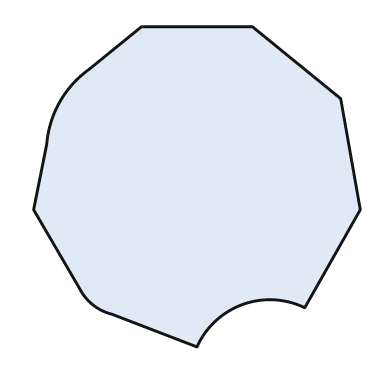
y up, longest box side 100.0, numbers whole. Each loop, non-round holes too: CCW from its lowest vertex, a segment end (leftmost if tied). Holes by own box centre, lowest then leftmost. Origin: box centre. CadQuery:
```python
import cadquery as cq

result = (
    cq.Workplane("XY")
    .moveTo(0.0, -49.0)
    .threePointArc((14.0, -36.0), (33.0, -37.0))
    .lineTo(50.0, -7.0)
    .lineTo(44.0, 27.0)
    .lineTo(17.0, 49.0)
    .lineTo(-17.0, 49.0)
    .lineTo(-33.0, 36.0)
    .threePointArc((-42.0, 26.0), (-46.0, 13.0))
    .lineTo(-50.0, -7.0)
    .lineTo(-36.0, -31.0)
    .threePointArc((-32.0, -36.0), (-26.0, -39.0))
    .close()
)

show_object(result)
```